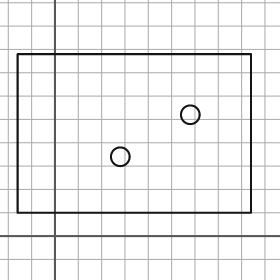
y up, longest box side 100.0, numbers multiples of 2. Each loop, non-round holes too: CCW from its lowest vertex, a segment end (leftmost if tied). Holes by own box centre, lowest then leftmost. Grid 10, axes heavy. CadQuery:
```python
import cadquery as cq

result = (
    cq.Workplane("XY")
    .moveTo(-16.0, 10.0)
    .lineTo(84.0, 10.0)
    .lineTo(84.0, 78.0)
    .lineTo(-16.0, 78.0)
    .close()
    .moveTo(28.0, 34.0)
    .circle(4.0)
    .moveTo(58.0, 52.0)
    .circle(4.0)
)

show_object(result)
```